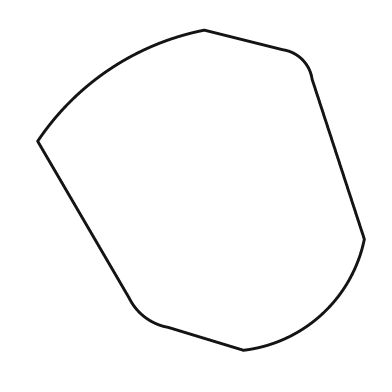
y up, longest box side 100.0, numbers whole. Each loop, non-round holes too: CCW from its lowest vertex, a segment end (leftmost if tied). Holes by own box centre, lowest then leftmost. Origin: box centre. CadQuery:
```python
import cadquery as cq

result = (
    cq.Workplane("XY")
    .moveTo(13.0, -49.0)
    .threePointArc((37.0, -38.0), (50.0, -15.0))
    .lineTo(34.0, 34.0)
    .threePointArc((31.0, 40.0), (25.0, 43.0))
    .lineTo(1.0, 49.0)
    .threePointArc((-28.0, 37.0), (-50.0, 15.0))
    .lineTo(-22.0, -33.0)
    .threePointArc((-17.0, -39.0), (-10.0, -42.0))
    .close()
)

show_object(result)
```